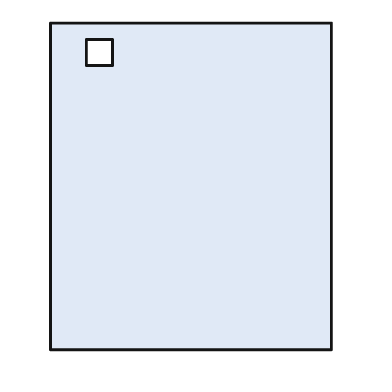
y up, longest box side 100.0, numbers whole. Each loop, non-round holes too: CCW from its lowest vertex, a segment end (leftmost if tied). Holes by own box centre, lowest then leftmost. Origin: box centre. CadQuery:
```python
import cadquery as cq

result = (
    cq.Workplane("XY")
    .moveTo(-43.0, -50.0)
    .lineTo(43.0, -50.0)
    .lineTo(43.0, 50.0)
    .lineTo(-43.0, 50.0)
    .close()
    .moveTo(-32.0, 37.0)
    .lineTo(-24.0, 37.0)
    .lineTo(-24.0, 45.0)
    .lineTo(-32.0, 45.0)
    .close()
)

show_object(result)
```